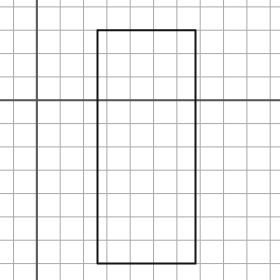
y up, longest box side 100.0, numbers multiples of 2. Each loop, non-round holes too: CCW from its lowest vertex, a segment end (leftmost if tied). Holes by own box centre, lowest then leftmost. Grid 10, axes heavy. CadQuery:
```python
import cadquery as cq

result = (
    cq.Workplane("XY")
    .moveTo(26.0, -70.0)
    .lineTo(68.0, -70.0)
    .lineTo(68.0, 30.0)
    .lineTo(26.0, 30.0)
    .close()
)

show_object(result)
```